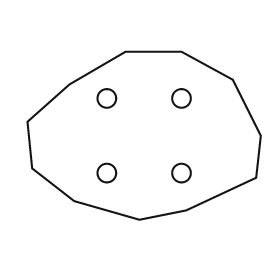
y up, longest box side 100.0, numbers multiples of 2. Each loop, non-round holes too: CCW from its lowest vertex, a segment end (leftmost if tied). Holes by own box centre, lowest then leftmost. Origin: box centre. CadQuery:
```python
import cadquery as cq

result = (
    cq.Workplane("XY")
    .moveTo(-2.0, -36.0)
    .lineTo(18.0, -32.0)
    .lineTo(48.0, -18.0)
    .lineTo(50.0, 0.0)
    .lineTo(38.0, 24.0)
    .lineTo(16.0, 36.0)
    .lineTo(-8.0, 36.0)
    .lineTo(-32.0, 22.0)
    .lineTo(-50.0, 6.0)
    .lineTo(-48.0, -14.0)
    .lineTo(-30.0, -28.0)
    .close()
    .moveTo(-16.0, -16.0)
    .circle(4.0)
    .moveTo(16.0, -16.0)
    .circle(4.0)
    .moveTo(-16.0, 16.0)
    .circle(4.0)
    .moveTo(16.0, 16.0)
    .circle(4.0)
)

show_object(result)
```